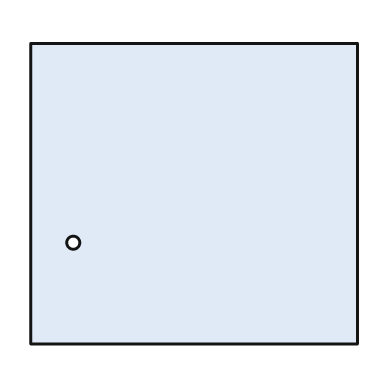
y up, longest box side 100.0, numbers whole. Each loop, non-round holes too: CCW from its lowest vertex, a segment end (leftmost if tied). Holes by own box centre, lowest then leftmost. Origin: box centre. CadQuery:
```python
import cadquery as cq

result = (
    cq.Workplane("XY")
    .moveTo(-50.0, -46.0)
    .lineTo(50.0, -46.0)
    .lineTo(50.0, 46.0)
    .lineTo(-50.0, 46.0)
    .close()
    .moveTo(-37.0, -15.0)
    .circle(2.0)
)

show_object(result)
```